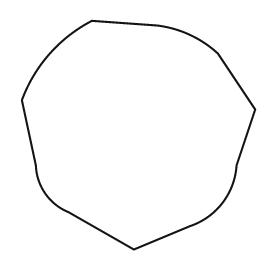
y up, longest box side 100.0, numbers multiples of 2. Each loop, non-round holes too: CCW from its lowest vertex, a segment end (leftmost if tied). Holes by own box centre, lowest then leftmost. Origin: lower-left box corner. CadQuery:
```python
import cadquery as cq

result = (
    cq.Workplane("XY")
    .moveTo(48.0, 0.0)
    .lineTo(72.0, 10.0)
    .threePointArc((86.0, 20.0), (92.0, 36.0))
    .lineTo(100.0, 60.0)
    .lineTo(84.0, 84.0)
    .threePointArc((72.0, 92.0), (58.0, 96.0))
    .lineTo(30.0, 98.0)
    .threePointArc((12.0, 84.0), (0.0, 64.0))
    .lineTo(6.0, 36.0)
    .threePointArc((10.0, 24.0), (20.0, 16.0))
    .close()
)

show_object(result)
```